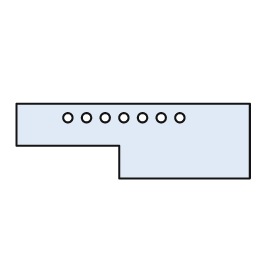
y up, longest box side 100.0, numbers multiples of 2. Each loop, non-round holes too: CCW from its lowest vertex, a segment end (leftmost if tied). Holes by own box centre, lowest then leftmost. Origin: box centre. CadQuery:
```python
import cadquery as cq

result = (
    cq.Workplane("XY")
    .moveTo(-6.0, -16.0)
    .lineTo(50.0, -16.0)
    .lineTo(50.0, 16.0)
    .lineTo(-50.0, 16.0)
    .lineTo(-50.0, -2.0)
    .lineTo(-6.0, -2.0)
    .close()
    .moveTo(-28.0, 10.0)
    .circle(2.0)
    .moveTo(-20.0, 10.0)
    .circle(2.0)
    .moveTo(-12.0, 10.0)
    .circle(2.0)
    .moveTo(-4.0, 10.0)
    .circle(2.0)
    .moveTo(4.0, 10.0)
    .circle(2.0)
    .moveTo(12.0, 10.0)
    .circle(2.0)
    .moveTo(20.0, 10.0)
    .circle(2.0)
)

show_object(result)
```